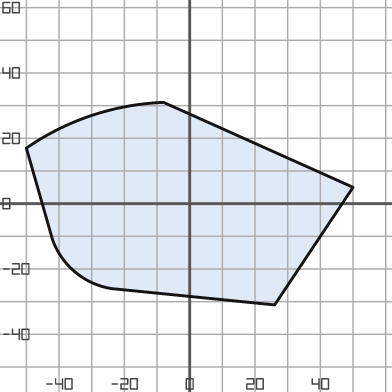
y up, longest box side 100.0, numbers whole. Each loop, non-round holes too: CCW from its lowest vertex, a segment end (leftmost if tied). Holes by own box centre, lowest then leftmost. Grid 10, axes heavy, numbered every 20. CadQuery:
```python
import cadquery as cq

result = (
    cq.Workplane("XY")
    .moveTo(26.0, -31.0)
    .lineTo(50.0, 5.0)
    .lineTo(-8.0, 31.0)
    .threePointArc((-30.0, 27.0), (-50.0, 17.0))
    .lineTo(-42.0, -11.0)
    .threePointArc((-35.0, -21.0), (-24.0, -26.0))
    .close()
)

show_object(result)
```